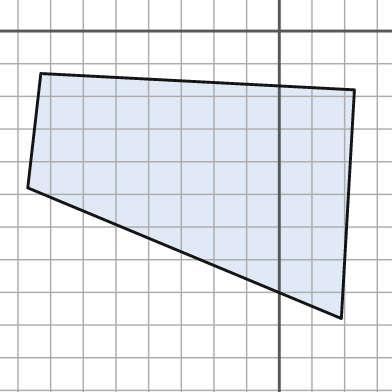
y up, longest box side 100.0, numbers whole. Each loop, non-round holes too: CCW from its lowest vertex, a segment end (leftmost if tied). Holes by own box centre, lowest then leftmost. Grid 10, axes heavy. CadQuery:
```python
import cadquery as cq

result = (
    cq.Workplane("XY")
    .moveTo(19.0, -88.0)
    .lineTo(23.0, -18.0)
    .lineTo(-73.0, -13.0)
    .lineTo(-77.0, -48.0)
    .close()
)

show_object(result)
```